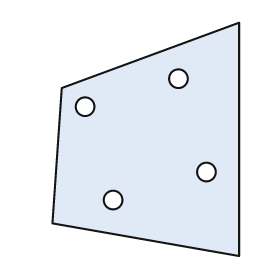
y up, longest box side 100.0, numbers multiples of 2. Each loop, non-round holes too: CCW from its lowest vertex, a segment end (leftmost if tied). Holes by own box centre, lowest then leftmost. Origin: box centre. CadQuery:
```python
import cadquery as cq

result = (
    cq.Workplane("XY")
    .moveTo(40.0, -50.0)
    .lineTo(40.0, 50.0)
    .lineTo(-36.0, 22.0)
    .lineTo(-40.0, -36.0)
    .close()
    .moveTo(-14.0, -26.0)
    .circle(4.0)
    .moveTo(26.0, -14.0)
    .circle(4.0)
    .moveTo(-26.0, 14.0)
    .circle(4.0)
    .moveTo(14.0, 26.0)
    .circle(4.0)
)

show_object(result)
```